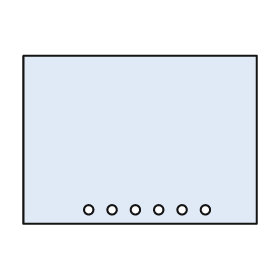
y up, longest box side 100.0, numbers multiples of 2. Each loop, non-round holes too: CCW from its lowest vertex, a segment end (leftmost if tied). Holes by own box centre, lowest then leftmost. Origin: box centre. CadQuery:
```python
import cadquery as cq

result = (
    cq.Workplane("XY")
    .moveTo(-50.0, -36.0)
    .lineTo(50.0, -36.0)
    .lineTo(50.0, 36.0)
    .lineTo(-50.0, 36.0)
    .close()
    .moveTo(-22.0, -30.0)
    .circle(2.0)
    .moveTo(-12.0, -30.0)
    .circle(2.0)
    .moveTo(-2.0, -30.0)
    .circle(2.0)
    .moveTo(8.0, -30.0)
    .circle(2.0)
    .moveTo(18.0, -30.0)
    .circle(2.0)
    .moveTo(28.0, -30.0)
    .circle(2.0)
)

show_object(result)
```